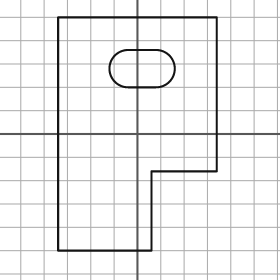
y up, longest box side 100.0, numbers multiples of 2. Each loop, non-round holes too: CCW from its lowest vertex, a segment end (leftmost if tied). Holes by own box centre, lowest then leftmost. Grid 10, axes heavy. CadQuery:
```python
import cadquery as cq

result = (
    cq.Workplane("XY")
    .moveTo(-34.0, -50.0)
    .lineTo(6.0, -50.0)
    .lineTo(6.0, -16.0)
    .lineTo(34.0, -16.0)
    .lineTo(34.0, 50.0)
    .lineTo(-34.0, 50.0)
    .close()
    .moveTo(-4.0, 20.0)
    .lineTo(8.0, 20.0)
    .threePointArc((16.0, 28.0), (8.0, 36.0))
    .lineTo(-4.0, 36.0)
    .threePointArc((-12.0, 28.0), (-4.0, 20.0))
    .close()
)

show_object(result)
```